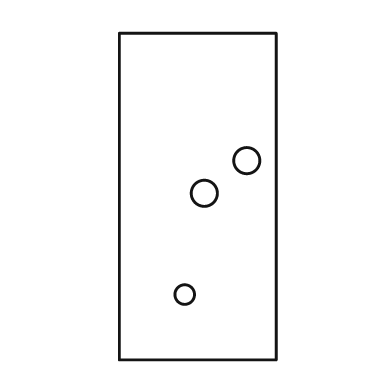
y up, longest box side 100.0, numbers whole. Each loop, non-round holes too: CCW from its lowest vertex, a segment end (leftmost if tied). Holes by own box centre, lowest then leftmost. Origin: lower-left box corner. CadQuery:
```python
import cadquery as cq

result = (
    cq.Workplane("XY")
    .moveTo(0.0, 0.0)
    .lineTo(48.0, 0.0)
    .lineTo(48.0, 100.0)
    .lineTo(0.0, 100.0)
    .close()
    .moveTo(20.0, 20.0)
    .circle(3.0)
    .moveTo(26.0, 51.0)
    .circle(4.0)
    .moveTo(39.0, 61.0)
    .circle(4.0)
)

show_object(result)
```